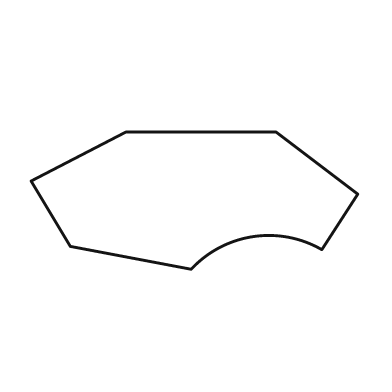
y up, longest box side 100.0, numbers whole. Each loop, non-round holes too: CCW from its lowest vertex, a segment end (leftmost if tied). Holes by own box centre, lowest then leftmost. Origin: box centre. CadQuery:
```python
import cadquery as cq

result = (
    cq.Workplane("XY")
    .moveTo(-1.0, -21.0)
    .threePointArc((18.0, -11.0), (39.0, -15.0))
    .lineTo(50.0, 2.0)
    .lineTo(25.0, 21.0)
    .lineTo(-21.0, 21.0)
    .lineTo(-50.0, 6.0)
    .lineTo(-38.0, -14.0)
    .close()
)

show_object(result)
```